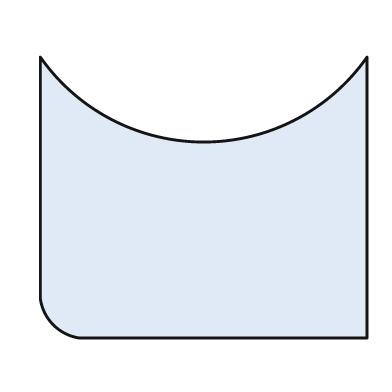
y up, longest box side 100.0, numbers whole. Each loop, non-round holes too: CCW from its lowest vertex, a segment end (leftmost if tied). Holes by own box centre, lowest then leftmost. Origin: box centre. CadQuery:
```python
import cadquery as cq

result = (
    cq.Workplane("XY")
    .moveTo(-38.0, -43.0)
    .lineTo(50.0, -43.0)
    .lineTo(50.0, 43.0)
    .threePointArc((0.0, 17.0), (-50.0, 43.0))
    .lineTo(-50.0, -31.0)
    .threePointArc((-46.0, -39.0), (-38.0, -43.0))
    .close()
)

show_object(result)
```